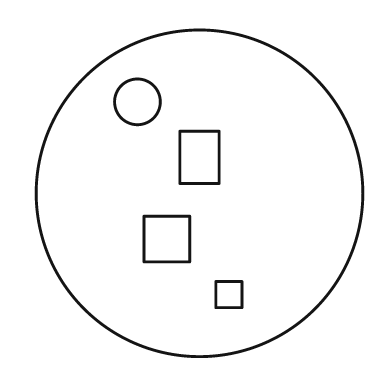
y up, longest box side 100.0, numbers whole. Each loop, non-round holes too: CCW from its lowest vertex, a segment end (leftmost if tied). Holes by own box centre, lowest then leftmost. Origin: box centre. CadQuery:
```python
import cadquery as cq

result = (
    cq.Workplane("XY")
    .moveTo(0.0, 0.0)
    .circle(50.0)
    .moveTo(5.0, -35.0)
    .lineTo(13.0, -35.0)
    .lineTo(13.0, -27.0)
    .lineTo(5.0, -27.0)
    .close()
    .moveTo(-17.0, -21.0)
    .lineTo(-3.0, -21.0)
    .lineTo(-3.0, -7.0)
    .lineTo(-17.0, -7.0)
    .close()
    .moveTo(-6.0, 3.0)
    .lineTo(6.0, 3.0)
    .lineTo(6.0, 19.0)
    .lineTo(-6.0, 19.0)
    .close()
    .moveTo(-19.0, 28.0)
    .circle(7.0)
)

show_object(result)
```